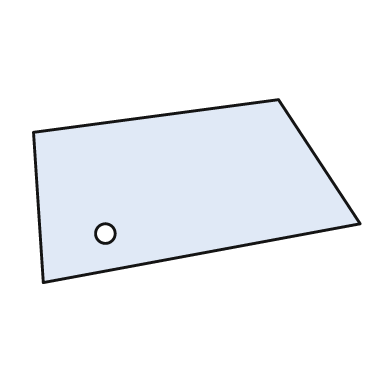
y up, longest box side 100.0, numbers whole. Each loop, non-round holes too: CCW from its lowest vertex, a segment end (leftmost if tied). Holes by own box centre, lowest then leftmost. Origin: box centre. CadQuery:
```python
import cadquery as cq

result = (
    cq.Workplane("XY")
    .moveTo(-47.0, -28.0)
    .lineTo(50.0, -10.0)
    .lineTo(25.0, 28.0)
    .lineTo(-50.0, 18.0)
    .close()
    .moveTo(-28.0, -13.0)
    .circle(3.0)
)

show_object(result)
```